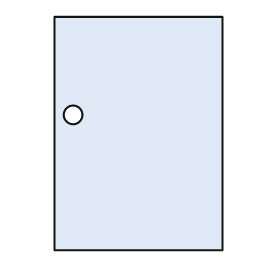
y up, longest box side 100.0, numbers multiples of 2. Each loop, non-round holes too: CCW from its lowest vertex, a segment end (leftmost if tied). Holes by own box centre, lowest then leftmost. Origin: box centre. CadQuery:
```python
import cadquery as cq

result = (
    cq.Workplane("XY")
    .moveTo(-36.0, -50.0)
    .lineTo(36.0, -50.0)
    .lineTo(36.0, 50.0)
    .lineTo(-36.0, 50.0)
    .close()
    .moveTo(-28.0, 8.0)
    .circle(4.0)
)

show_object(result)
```